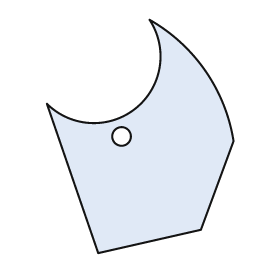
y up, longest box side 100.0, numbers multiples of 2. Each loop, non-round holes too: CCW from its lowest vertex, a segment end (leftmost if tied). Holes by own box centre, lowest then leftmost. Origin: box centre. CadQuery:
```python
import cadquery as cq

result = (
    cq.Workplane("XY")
    .moveTo(-18.0, -50.0)
    .lineTo(26.0, -40.0)
    .lineTo(40.0, -2.0)
    .threePointArc((28.0, 28.0), (4.0, 50.0))
    .threePointArc((-2.0, 12.0), (-40.0, 14.0))
    .close()
    .moveTo(-8.0, 0.0)
    .circle(4.0)
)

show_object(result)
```